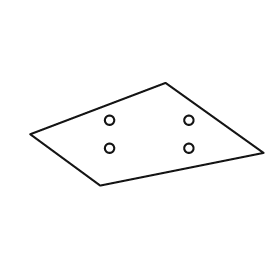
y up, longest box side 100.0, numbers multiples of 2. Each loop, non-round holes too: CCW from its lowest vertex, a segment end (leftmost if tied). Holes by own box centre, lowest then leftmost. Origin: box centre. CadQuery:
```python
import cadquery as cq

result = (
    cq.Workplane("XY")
    .moveTo(-20.0, -22.0)
    .lineTo(50.0, -8.0)
    .lineTo(8.0, 22.0)
    .lineTo(-50.0, 0.0)
    .close()
    .moveTo(-16.0, -6.0)
    .circle(2.0)
    .moveTo(18.0, -6.0)
    .circle(2.0)
    .moveTo(-16.0, 6.0)
    .circle(2.0)
    .moveTo(18.0, 6.0)
    .circle(2.0)
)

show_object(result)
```